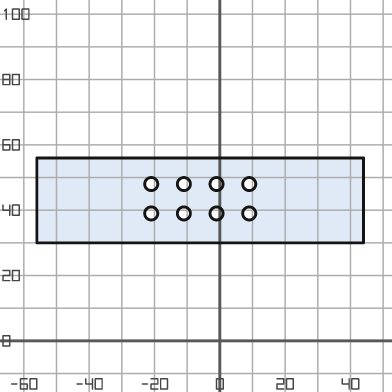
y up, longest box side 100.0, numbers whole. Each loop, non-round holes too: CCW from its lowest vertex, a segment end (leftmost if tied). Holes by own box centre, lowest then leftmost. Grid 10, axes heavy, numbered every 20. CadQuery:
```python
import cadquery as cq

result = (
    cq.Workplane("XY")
    .moveTo(-56.0, 30.0)
    .lineTo(44.0, 30.0)
    .lineTo(44.0, 56.0)
    .lineTo(-56.0, 56.0)
    .close()
    .moveTo(-21.0, 39.0)
    .circle(2.0)
    .moveTo(-11.0, 39.0)
    .circle(2.0)
    .moveTo(-1.0, 39.0)
    .circle(2.0)
    .moveTo(9.0, 39.0)
    .circle(2.0)
    .moveTo(-21.0, 48.0)
    .circle(2.0)
    .moveTo(-11.0, 48.0)
    .circle(2.0)
    .moveTo(-1.0, 48.0)
    .circle(2.0)
    .moveTo(9.0, 48.0)
    .circle(2.0)
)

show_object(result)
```